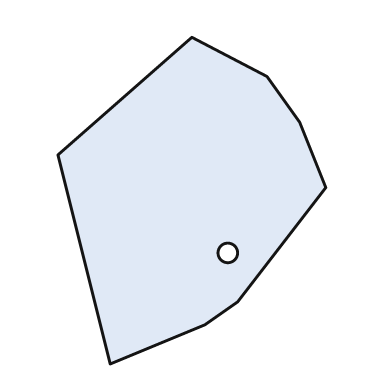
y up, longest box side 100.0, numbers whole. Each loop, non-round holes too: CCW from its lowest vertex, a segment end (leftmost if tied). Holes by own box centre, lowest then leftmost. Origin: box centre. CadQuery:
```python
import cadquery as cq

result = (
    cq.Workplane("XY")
    .moveTo(-25.0, -50.0)
    .lineTo(4.0, -38.0)
    .lineTo(14.0, -31.0)
    .lineTo(41.0, 4.0)
    .lineTo(33.0, 24.0)
    .lineTo(23.0, 38.0)
    .lineTo(0.0, 50.0)
    .lineTo(-41.0, 14.0)
    .close()
    .moveTo(11.0, -16.0)
    .circle(3.0)
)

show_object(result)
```